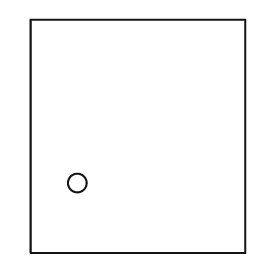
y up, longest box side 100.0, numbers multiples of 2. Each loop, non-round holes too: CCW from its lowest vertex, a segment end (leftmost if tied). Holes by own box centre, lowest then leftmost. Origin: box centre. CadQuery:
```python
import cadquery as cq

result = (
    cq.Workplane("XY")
    .moveTo(-46.0, -50.0)
    .lineTo(46.0, -50.0)
    .lineTo(46.0, 50.0)
    .lineTo(-46.0, 50.0)
    .close()
    .moveTo(-26.0, -20.0)
    .circle(4.0)
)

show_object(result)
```